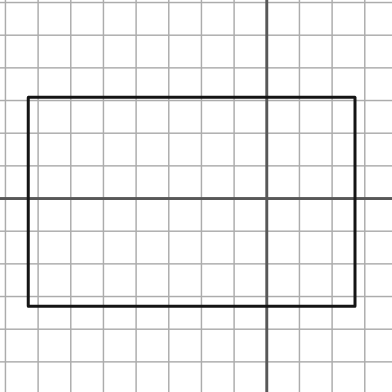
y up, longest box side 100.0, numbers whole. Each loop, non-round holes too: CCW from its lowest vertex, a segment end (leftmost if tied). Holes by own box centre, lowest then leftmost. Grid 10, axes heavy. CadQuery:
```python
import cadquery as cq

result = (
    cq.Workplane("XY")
    .moveTo(-73.0, -33.0)
    .lineTo(27.0, -33.0)
    .lineTo(27.0, 31.0)
    .lineTo(-73.0, 31.0)
    .close()
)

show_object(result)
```